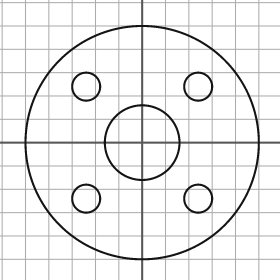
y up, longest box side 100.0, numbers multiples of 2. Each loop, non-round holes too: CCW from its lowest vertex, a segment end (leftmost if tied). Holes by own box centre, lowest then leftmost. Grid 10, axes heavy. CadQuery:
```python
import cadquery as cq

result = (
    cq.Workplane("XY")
    .moveTo(0.0, 0.0)
    .circle(50.0)
    .moveTo(-24.0, -24.0)
    .circle(6.0)
    .moveTo(24.0, -24.0)
    .circle(6.0)
    .moveTo(0.0, 0.0)
    .circle(16.0)
    .moveTo(-24.0, 24.0)
    .circle(6.0)
    .moveTo(24.0, 24.0)
    .circle(6.0)
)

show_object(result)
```